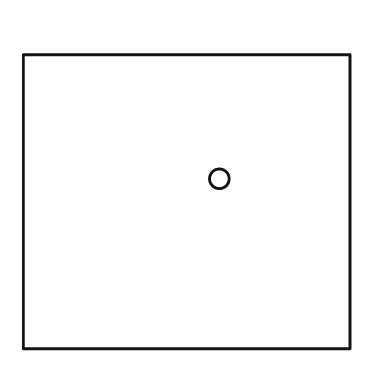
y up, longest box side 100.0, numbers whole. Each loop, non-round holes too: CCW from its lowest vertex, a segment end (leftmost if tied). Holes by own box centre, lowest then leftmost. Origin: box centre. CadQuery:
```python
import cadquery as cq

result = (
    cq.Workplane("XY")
    .moveTo(-50.0, -45.0)
    .lineTo(50.0, -45.0)
    .lineTo(50.0, 45.0)
    .lineTo(-50.0, 45.0)
    .close()
    .moveTo(10.0, 7.0)
    .circle(3.0)
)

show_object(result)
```